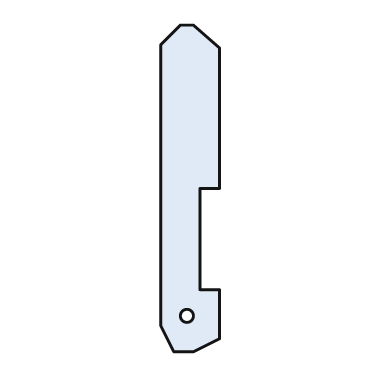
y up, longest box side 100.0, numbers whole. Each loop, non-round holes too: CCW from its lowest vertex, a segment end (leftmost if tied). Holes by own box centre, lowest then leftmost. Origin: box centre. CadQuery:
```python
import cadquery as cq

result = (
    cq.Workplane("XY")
    .moveTo(-5.0, -50.0)
    .lineTo(1.0, -50.0)
    .lineTo(9.0, -46.0)
    .lineTo(9.0, -31.0)
    .lineTo(3.0, -31.0)
    .lineTo(3.0, 0.0)
    .lineTo(9.0, 0.0)
    .lineTo(9.0, 43.0)
    .lineTo(1.0, 50.0)
    .lineTo(-3.0, 50.0)
    .lineTo(-9.0, 44.0)
    .lineTo(-9.0, -42.0)
    .close()
    .moveTo(-1.0, -39.0)
    .circle(2.0)
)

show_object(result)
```